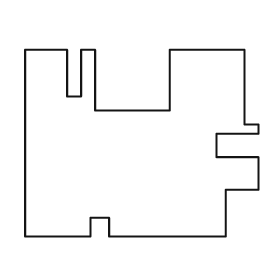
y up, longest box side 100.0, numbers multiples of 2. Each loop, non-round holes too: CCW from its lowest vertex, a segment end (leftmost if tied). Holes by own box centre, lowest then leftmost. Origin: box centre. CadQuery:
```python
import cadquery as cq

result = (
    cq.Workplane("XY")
    .moveTo(-50.0, -40.0)
    .lineTo(-22.0, -40.0)
    .lineTo(-22.0, -32.0)
    .lineTo(-14.0, -32.0)
    .lineTo(-14.0, -40.0)
    .lineTo(36.0, -40.0)
    .lineTo(36.0, -20.0)
    .lineTo(50.0, -20.0)
    .lineTo(50.0, -6.0)
    .lineTo(32.0, -6.0)
    .lineTo(32.0, 4.0)
    .lineTo(50.0, 4.0)
    .lineTo(50.0, 8.0)
    .lineTo(44.0, 8.0)
    .lineTo(44.0, 40.0)
    .lineTo(12.0, 40.0)
    .lineTo(12.0, 14.0)
    .lineTo(-20.0, 14.0)
    .lineTo(-20.0, 40.0)
    .lineTo(-26.0, 40.0)
    .lineTo(-26.0, 20.0)
    .lineTo(-32.0, 20.0)
    .lineTo(-32.0, 40.0)
    .lineTo(-50.0, 40.0)
    .close()
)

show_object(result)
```